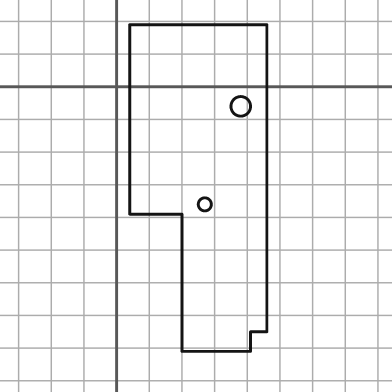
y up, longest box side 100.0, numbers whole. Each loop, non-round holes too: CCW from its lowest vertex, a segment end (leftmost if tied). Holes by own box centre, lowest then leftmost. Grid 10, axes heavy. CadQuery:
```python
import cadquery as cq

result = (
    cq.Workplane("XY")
    .moveTo(20.0, -81.0)
    .lineTo(41.0, -81.0)
    .lineTo(41.0, -75.0)
    .lineTo(46.0, -75.0)
    .lineTo(46.0, 19.0)
    .lineTo(4.0, 19.0)
    .lineTo(4.0, -39.0)
    .lineTo(20.0, -39.0)
    .close()
    .moveTo(27.0, -36.0)
    .circle(2.0)
    .moveTo(38.0, -6.0)
    .circle(3.0)
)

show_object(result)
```